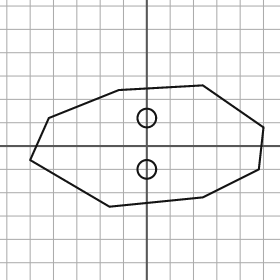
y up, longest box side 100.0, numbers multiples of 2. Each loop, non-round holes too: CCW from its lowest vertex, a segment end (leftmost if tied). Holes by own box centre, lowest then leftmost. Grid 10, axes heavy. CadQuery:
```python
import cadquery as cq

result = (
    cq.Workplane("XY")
    .moveTo(-16.0, -26.0)
    .lineTo(24.0, -22.0)
    .lineTo(48.0, -10.0)
    .lineTo(50.0, 8.0)
    .lineTo(24.0, 26.0)
    .lineTo(-12.0, 24.0)
    .lineTo(-42.0, 12.0)
    .lineTo(-50.0, -6.0)
    .close()
    .moveTo(0.0, -10.0)
    .circle(4.0)
    .moveTo(0.0, 12.0)
    .circle(4.0)
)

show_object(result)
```